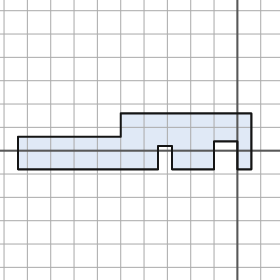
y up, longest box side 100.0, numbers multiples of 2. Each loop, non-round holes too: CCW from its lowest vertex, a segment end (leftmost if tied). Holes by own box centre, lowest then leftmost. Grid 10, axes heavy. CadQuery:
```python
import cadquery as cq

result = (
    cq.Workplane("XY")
    .moveTo(-94.0, -8.0)
    .lineTo(-34.0, -8.0)
    .lineTo(-34.0, 2.0)
    .lineTo(-28.0, 2.0)
    .lineTo(-28.0, -8.0)
    .lineTo(-10.0, -8.0)
    .lineTo(-10.0, 4.0)
    .lineTo(0.0, 4.0)
    .lineTo(0.0, -8.0)
    .lineTo(6.0, -8.0)
    .lineTo(6.0, 16.0)
    .lineTo(-50.0, 16.0)
    .lineTo(-50.0, 6.0)
    .lineTo(-94.0, 6.0)
    .close()
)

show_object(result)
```